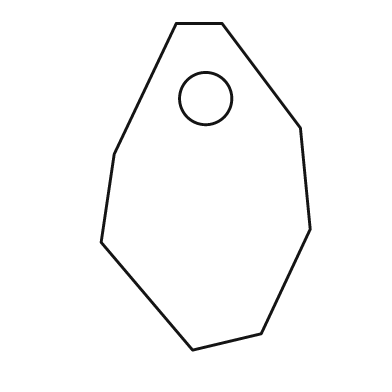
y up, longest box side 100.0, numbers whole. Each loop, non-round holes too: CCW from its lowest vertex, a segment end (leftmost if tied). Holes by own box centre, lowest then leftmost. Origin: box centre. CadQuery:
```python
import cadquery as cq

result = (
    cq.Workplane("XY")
    .moveTo(-4.0, -50.0)
    .lineTo(17.0, -45.0)
    .lineTo(32.0, -13.0)
    .lineTo(29.0, 18.0)
    .lineTo(5.0, 50.0)
    .lineTo(-9.0, 50.0)
    .lineTo(-28.0, 10.0)
    .lineTo(-32.0, -17.0)
    .close()
    .moveTo(0.0, 27.0)
    .circle(8.0)
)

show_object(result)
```